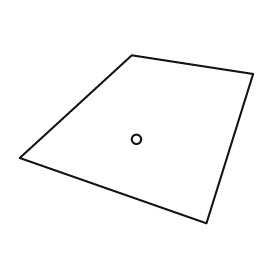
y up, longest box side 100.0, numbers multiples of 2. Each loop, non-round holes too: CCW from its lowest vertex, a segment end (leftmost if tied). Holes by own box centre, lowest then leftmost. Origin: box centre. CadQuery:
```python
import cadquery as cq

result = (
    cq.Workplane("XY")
    .moveTo(30.0, -36.0)
    .lineTo(50.0, 28.0)
    .lineTo(-2.0, 36.0)
    .lineTo(-50.0, -8.0)
    .close()
    .moveTo(0.0, 0.0)
    .circle(2.0)
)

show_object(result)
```